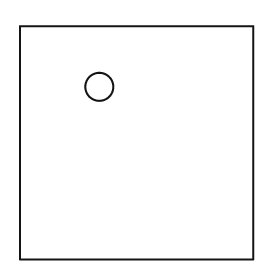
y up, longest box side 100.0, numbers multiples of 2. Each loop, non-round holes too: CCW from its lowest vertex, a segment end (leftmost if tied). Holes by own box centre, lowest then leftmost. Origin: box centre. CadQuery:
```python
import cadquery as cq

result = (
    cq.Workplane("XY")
    .moveTo(-50.0, -50.0)
    .lineTo(50.0, -50.0)
    .lineTo(50.0, 50.0)
    .lineTo(-50.0, 50.0)
    .close()
    .moveTo(-16.0, 24.0)
    .circle(6.0)
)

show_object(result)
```